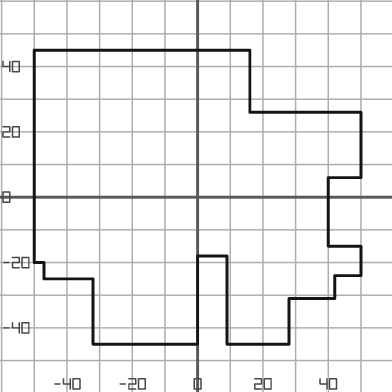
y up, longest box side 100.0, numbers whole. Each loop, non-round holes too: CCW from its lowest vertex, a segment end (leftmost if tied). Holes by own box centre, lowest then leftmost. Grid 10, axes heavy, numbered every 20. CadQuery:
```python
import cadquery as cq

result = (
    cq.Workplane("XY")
    .moveTo(-32.0, -45.0)
    .lineTo(0.0, -45.0)
    .lineTo(0.0, -18.0)
    .lineTo(9.0, -18.0)
    .lineTo(9.0, -45.0)
    .lineTo(28.0, -45.0)
    .lineTo(28.0, -31.0)
    .lineTo(42.0, -31.0)
    .lineTo(42.0, -24.0)
    .lineTo(50.0, -24.0)
    .lineTo(50.0, -15.0)
    .lineTo(40.0, -15.0)
    .lineTo(40.0, 6.0)
    .lineTo(50.0, 6.0)
    .lineTo(50.0, 26.0)
    .lineTo(16.0, 26.0)
    .lineTo(16.0, 45.0)
    .lineTo(-50.0, 45.0)
    .lineTo(-50.0, -20.0)
    .lineTo(-47.0, -20.0)
    .lineTo(-47.0, -25.0)
    .lineTo(-32.0, -25.0)
    .close()
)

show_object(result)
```